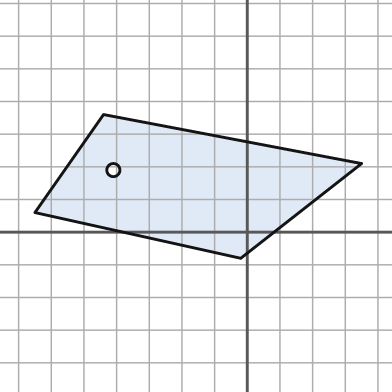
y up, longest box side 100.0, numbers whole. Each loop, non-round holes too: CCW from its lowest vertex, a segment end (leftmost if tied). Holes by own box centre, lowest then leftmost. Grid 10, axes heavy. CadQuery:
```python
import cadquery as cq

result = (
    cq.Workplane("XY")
    .moveTo(-2.0, -8.0)
    .lineTo(35.0, 21.0)
    .lineTo(-44.0, 36.0)
    .lineTo(-65.0, 6.0)
    .close()
    .moveTo(-41.0, 19.0)
    .circle(2.0)
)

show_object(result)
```